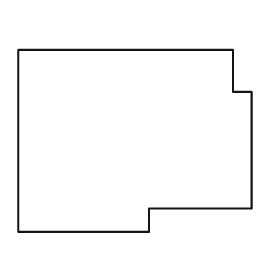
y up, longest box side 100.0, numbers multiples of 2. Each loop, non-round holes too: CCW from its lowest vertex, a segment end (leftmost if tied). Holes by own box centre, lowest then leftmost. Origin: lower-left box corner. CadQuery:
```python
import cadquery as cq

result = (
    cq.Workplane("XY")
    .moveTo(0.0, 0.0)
    .lineTo(56.0, 0.0)
    .lineTo(56.0, 10.0)
    .lineTo(100.0, 10.0)
    .lineTo(100.0, 60.0)
    .lineTo(92.0, 60.0)
    .lineTo(92.0, 78.0)
    .lineTo(0.0, 78.0)
    .close()
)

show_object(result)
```